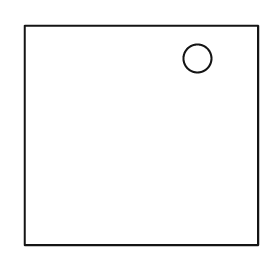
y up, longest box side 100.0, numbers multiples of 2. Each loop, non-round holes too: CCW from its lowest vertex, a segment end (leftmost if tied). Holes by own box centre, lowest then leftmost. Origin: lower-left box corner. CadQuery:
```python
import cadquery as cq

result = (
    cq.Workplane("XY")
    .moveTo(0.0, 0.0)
    .lineTo(100.0, 0.0)
    .lineTo(100.0, 94.0)
    .lineTo(0.0, 94.0)
    .close()
    .moveTo(74.0, 80.0)
    .circle(6.0)
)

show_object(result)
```